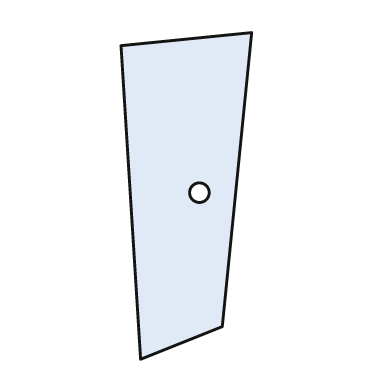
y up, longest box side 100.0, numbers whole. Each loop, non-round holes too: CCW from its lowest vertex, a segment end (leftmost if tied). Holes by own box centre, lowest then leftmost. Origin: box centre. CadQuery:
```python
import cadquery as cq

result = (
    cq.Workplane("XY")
    .moveTo(-14.0, -50.0)
    .lineTo(11.0, -40.0)
    .lineTo(20.0, 50.0)
    .lineTo(-20.0, 46.0)
    .close()
    .moveTo(4.0, 1.0)
    .circle(3.0)
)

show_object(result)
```